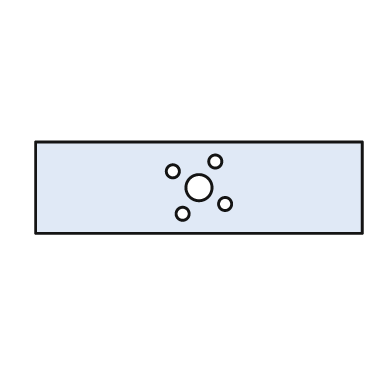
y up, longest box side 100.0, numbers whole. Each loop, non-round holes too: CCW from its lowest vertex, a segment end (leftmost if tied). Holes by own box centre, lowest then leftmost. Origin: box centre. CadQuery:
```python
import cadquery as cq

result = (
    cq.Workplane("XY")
    .moveTo(-50.0, -14.0)
    .lineTo(50.0, -14.0)
    .lineTo(50.0, 14.0)
    .lineTo(-50.0, 14.0)
    .close()
    .moveTo(-5.0, -8.0)
    .circle(2.0)
    .moveTo(8.0, -5.0)
    .circle(2.0)
    .moveTo(0.0, 0.0)
    .circle(4.0)
    .moveTo(-8.0, 5.0)
    .circle(2.0)
    .moveTo(5.0, 8.0)
    .circle(2.0)
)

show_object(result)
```